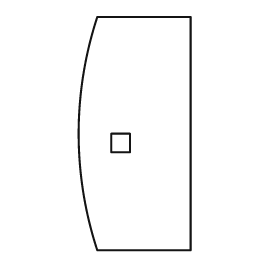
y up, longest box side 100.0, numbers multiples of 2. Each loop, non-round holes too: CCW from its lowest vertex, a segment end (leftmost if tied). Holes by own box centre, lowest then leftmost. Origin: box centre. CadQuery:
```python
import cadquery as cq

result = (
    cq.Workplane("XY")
    .moveTo(-16.0, -50.0)
    .lineTo(24.0, -50.0)
    .lineTo(24.0, 50.0)
    .lineTo(-16.0, 50.0)
    .threePointArc((-24.0, 0.0), (-16.0, -50.0))
    .close()
    .moveTo(-10.0, -8.0)
    .lineTo(-2.0, -8.0)
    .lineTo(-2.0, 0.0)
    .lineTo(-10.0, 0.0)
    .close()
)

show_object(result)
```